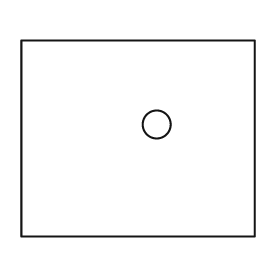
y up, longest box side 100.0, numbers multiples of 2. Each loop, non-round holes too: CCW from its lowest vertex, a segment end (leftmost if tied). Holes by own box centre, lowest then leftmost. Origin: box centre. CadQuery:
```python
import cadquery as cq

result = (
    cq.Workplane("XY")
    .moveTo(-50.0, -42.0)
    .lineTo(50.0, -42.0)
    .lineTo(50.0, 42.0)
    .lineTo(-50.0, 42.0)
    .close()
    .moveTo(8.0, 6.0)
    .circle(6.0)
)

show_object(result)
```